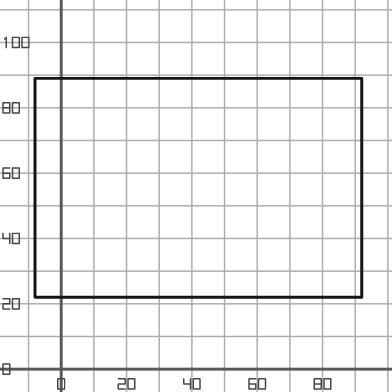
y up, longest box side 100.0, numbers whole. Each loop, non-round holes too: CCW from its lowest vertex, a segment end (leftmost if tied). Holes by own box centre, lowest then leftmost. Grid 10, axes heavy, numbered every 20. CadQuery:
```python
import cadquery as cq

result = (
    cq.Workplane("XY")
    .moveTo(-8.0, 22.0)
    .lineTo(92.0, 22.0)
    .lineTo(92.0, 89.0)
    .lineTo(-8.0, 89.0)
    .close()
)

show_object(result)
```